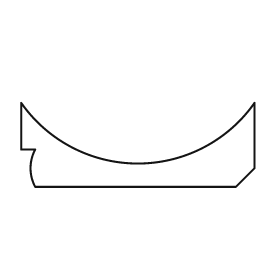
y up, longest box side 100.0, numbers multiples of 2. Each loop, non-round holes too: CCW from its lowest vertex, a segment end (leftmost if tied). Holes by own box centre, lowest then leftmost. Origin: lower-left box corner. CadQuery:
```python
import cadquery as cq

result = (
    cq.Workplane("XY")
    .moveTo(6.0, 0.0)
    .lineTo(92.0, 0.0)
    .lineTo(100.0, 8.0)
    .lineTo(100.0, 36.0)
    .threePointArc((50.0, 10.0), (0.0, 36.0))
    .lineTo(0.0, 16.0)
    .lineTo(6.0, 16.0)
    .threePointArc((4.0, 8.0), (6.0, 0.0))
    .close()
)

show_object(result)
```